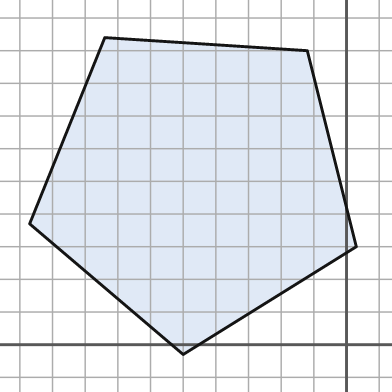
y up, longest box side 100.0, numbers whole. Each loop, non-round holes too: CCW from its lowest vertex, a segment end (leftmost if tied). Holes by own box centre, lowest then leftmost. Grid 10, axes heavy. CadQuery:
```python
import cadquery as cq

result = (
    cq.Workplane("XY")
    .moveTo(-50.0, -3.0)
    .lineTo(3.0, 30.0)
    .lineTo(-12.0, 90.0)
    .lineTo(-74.0, 94.0)
    .lineTo(-97.0, 37.0)
    .close()
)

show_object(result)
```